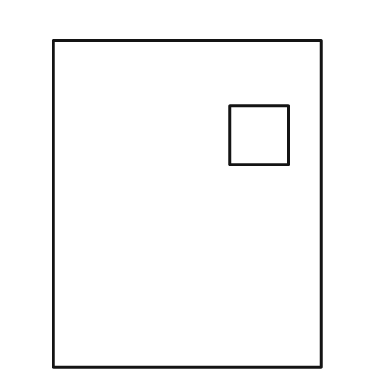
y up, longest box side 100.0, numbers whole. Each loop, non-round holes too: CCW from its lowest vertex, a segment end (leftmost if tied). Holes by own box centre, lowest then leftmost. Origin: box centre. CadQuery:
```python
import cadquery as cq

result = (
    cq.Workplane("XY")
    .moveTo(-41.0, -50.0)
    .lineTo(41.0, -50.0)
    .lineTo(41.0, 50.0)
    .lineTo(-41.0, 50.0)
    .close()
    .moveTo(13.0, 12.0)
    .lineTo(31.0, 12.0)
    .lineTo(31.0, 30.0)
    .lineTo(13.0, 30.0)
    .close()
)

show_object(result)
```